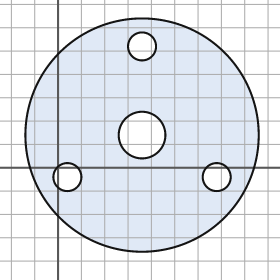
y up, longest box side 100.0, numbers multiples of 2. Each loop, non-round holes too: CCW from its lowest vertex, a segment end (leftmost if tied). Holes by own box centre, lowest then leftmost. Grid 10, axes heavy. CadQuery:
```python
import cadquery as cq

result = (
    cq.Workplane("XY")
    .moveTo(36.0, 14.0)
    .circle(50.0)
    .moveTo(4.0, -4.0)
    .circle(6.0)
    .moveTo(68.0, -4.0)
    .circle(6.0)
    .moveTo(36.0, 14.0)
    .circle(10.0)
    .moveTo(36.0, 52.0)
    .circle(6.0)
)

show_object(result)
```